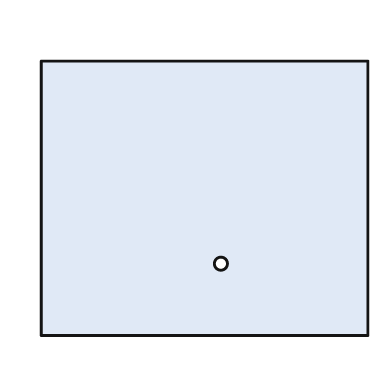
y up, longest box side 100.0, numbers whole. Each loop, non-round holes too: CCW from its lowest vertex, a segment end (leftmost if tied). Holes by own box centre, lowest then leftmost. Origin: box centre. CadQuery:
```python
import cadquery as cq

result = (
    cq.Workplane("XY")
    .moveTo(-50.0, -42.0)
    .lineTo(50.0, -42.0)
    .lineTo(50.0, 42.0)
    .lineTo(-50.0, 42.0)
    .close()
    .moveTo(5.0, -20.0)
    .circle(2.0)
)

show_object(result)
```